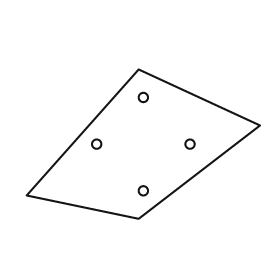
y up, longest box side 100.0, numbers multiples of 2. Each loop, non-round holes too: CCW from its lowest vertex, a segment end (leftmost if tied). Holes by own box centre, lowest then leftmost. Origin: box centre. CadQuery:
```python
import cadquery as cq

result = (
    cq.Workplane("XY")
    .moveTo(-2.0, -32.0)
    .lineTo(50.0, 8.0)
    .lineTo(-2.0, 32.0)
    .lineTo(-50.0, -22.0)
    .close()
    .moveTo(0.0, -20.0)
    .circle(2.0)
    .moveTo(-20.0, 0.0)
    .circle(2.0)
    .moveTo(20.0, 0.0)
    .circle(2.0)
    .moveTo(0.0, 20.0)
    .circle(2.0)
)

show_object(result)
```